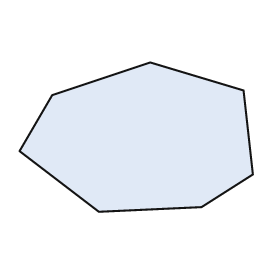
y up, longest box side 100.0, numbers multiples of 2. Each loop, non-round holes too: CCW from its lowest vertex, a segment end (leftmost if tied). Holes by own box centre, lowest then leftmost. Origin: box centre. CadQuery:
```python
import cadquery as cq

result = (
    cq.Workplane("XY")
    .moveTo(-16.0, -32.0)
    .lineTo(28.0, -30.0)
    .lineTo(50.0, -16.0)
    .lineTo(46.0, 20.0)
    .lineTo(6.0, 32.0)
    .lineTo(-36.0, 18.0)
    .lineTo(-50.0, -6.0)
    .close()
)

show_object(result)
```